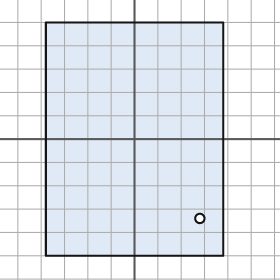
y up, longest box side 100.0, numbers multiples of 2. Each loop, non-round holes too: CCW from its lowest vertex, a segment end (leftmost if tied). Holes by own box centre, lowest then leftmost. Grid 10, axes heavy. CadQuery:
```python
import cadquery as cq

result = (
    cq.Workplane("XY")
    .moveTo(-38.0, -50.0)
    .lineTo(38.0, -50.0)
    .lineTo(38.0, 50.0)
    .lineTo(-38.0, 50.0)
    .close()
    .moveTo(28.0, -34.0)
    .circle(2.0)
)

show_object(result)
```